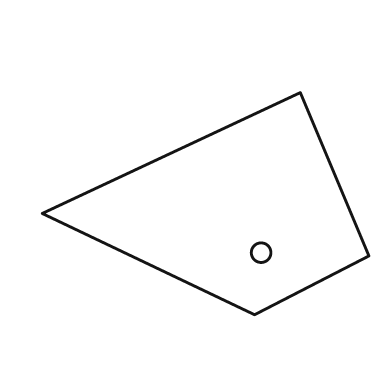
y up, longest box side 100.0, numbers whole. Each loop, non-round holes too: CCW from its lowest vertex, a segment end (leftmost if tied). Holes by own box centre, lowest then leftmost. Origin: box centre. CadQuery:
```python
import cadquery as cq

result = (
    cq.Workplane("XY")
    .moveTo(15.0, -34.0)
    .lineTo(50.0, -16.0)
    .lineTo(29.0, 34.0)
    .lineTo(-50.0, -3.0)
    .close()
    .moveTo(17.0, -15.0)
    .circle(3.0)
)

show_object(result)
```